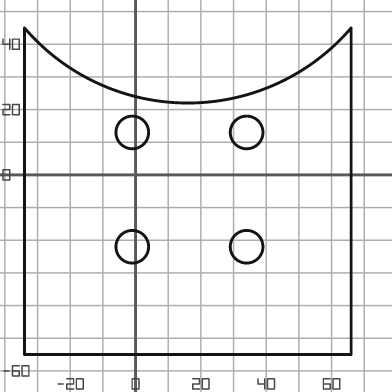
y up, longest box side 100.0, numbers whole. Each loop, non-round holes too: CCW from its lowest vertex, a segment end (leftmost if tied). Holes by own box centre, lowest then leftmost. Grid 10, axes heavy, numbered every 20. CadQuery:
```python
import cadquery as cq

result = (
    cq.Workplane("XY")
    .moveTo(-34.0, -55.0)
    .lineTo(66.0, -55.0)
    .lineTo(66.0, 45.0)
    .threePointArc((16.0, 22.0), (-34.0, 45.0))
    .close()
    .moveTo(-1.0, -22.0)
    .circle(5.0)
    .moveTo(34.0, -22.0)
    .circle(5.0)
    .moveTo(-1.0, 13.0)
    .circle(5.0)
    .moveTo(34.0, 13.0)
    .circle(5.0)
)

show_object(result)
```